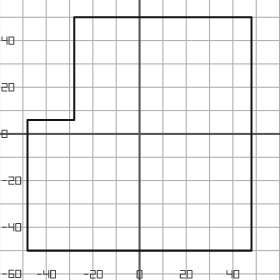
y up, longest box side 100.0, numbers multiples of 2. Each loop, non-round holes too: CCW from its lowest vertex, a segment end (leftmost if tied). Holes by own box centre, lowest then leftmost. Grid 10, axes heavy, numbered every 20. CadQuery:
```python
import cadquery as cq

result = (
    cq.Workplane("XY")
    .moveTo(-48.0, -50.0)
    .lineTo(48.0, -50.0)
    .lineTo(48.0, 50.0)
    .lineTo(-28.0, 50.0)
    .lineTo(-28.0, 6.0)
    .lineTo(-48.0, 6.0)
    .close()
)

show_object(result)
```